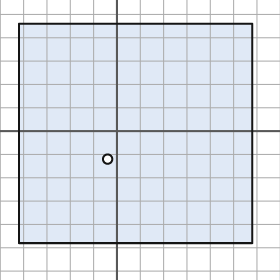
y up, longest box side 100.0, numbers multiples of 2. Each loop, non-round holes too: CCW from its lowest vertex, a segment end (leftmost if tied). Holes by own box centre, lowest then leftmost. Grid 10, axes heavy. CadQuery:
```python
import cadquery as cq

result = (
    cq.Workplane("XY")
    .moveTo(-42.0, -48.0)
    .lineTo(58.0, -48.0)
    .lineTo(58.0, 46.0)
    .lineTo(-42.0, 46.0)
    .close()
    .moveTo(-4.0, -12.0)
    .circle(2.0)
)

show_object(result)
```